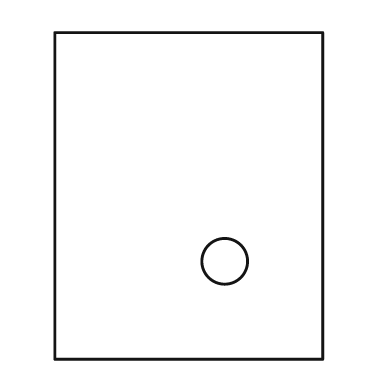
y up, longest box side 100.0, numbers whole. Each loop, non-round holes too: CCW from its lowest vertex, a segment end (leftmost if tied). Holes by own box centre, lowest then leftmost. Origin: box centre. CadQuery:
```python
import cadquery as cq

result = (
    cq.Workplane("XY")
    .moveTo(-41.0, -50.0)
    .lineTo(41.0, -50.0)
    .lineTo(41.0, 50.0)
    .lineTo(-41.0, 50.0)
    .close()
    .moveTo(11.0, -20.0)
    .circle(7.0)
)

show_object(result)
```